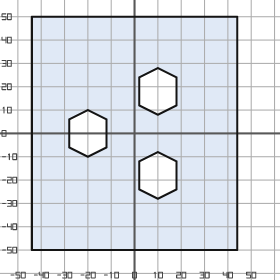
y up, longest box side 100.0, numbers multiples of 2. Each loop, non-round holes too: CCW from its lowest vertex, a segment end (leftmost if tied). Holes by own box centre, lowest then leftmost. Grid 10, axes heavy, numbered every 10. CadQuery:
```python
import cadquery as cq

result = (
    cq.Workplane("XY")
    .moveTo(-44.0, -50.0)
    .lineTo(44.0, -50.0)
    .lineTo(44.0, 50.0)
    .lineTo(-44.0, 50.0)
    .close()
    .moveTo(10.0, -28.0)
    .lineTo(18.0, -24.0)
    .lineTo(18.0, -12.0)
    .lineTo(10.0, -8.0)
    .lineTo(2.0, -12.0)
    .lineTo(2.0, -24.0)
    .close()
    .moveTo(-20.0, -10.0)
    .lineTo(-12.0, -6.0)
    .lineTo(-12.0, 6.0)
    .lineTo(-20.0, 10.0)
    .lineTo(-28.0, 6.0)
    .lineTo(-28.0, -6.0)
    .close()
    .moveTo(10.0, 8.0)
    .lineTo(18.0, 12.0)
    .lineTo(18.0, 24.0)
    .lineTo(10.0, 28.0)
    .lineTo(2.0, 24.0)
    .lineTo(2.0, 12.0)
    .close()
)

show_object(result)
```